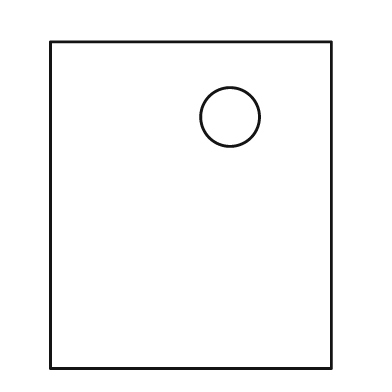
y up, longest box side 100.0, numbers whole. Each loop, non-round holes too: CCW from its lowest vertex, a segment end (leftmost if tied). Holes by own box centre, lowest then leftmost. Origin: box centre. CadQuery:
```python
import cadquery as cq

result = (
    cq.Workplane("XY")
    .moveTo(-43.0, -50.0)
    .lineTo(43.0, -50.0)
    .lineTo(43.0, 50.0)
    .lineTo(-43.0, 50.0)
    .close()
    .moveTo(12.0, 27.0)
    .circle(9.0)
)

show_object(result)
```